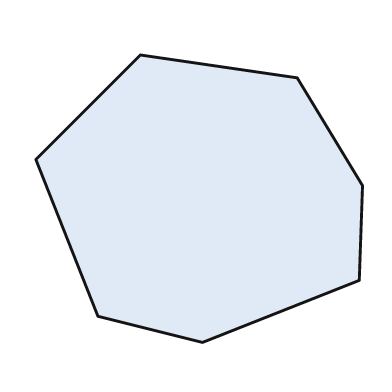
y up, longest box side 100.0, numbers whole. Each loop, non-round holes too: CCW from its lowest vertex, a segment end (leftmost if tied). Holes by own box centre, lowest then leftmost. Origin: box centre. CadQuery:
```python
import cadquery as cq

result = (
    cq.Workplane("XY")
    .moveTo(1.0, -44.0)
    .lineTo(49.0, -25.0)
    .lineTo(50.0, 4.0)
    .lineTo(30.0, 37.0)
    .lineTo(-18.0, 44.0)
    .lineTo(-50.0, 12.0)
    .lineTo(-31.0, -36.0)
    .close()
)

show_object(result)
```